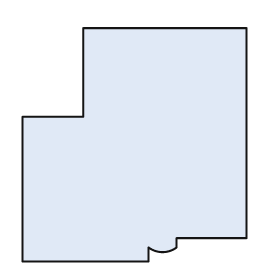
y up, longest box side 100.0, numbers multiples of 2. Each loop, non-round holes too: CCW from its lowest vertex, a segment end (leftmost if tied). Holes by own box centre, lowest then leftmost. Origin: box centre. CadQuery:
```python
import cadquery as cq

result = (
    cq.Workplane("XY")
    .moveTo(-48.0, -50.0)
    .lineTo(6.0, -50.0)
    .lineTo(6.0, -44.0)
    .threePointArc((12.0, -46.0), (18.0, -44.0))
    .lineTo(18.0, -40.0)
    .lineTo(48.0, -40.0)
    .lineTo(48.0, 50.0)
    .lineTo(-22.0, 50.0)
    .lineTo(-22.0, 12.0)
    .lineTo(-48.0, 12.0)
    .close()
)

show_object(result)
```